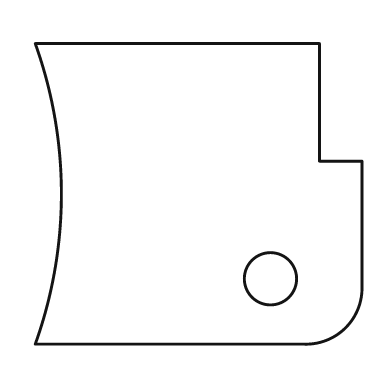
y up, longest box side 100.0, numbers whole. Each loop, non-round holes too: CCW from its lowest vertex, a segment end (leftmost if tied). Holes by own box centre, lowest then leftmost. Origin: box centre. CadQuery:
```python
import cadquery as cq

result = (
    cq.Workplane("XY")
    .moveTo(-50.0, -46.0)
    .lineTo(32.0, -46.0)
    .threePointArc((45.0, -41.0), (50.0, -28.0))
    .lineTo(50.0, 10.0)
    .lineTo(37.0, 10.0)
    .lineTo(37.0, 46.0)
    .lineTo(-50.0, 46.0)
    .threePointArc((-42.0, 0.0), (-50.0, -46.0))
    .close()
    .moveTo(22.0, -26.0)
    .circle(8.0)
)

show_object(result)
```